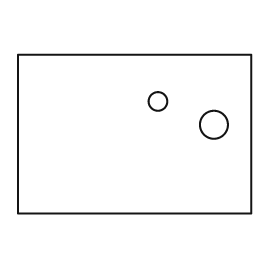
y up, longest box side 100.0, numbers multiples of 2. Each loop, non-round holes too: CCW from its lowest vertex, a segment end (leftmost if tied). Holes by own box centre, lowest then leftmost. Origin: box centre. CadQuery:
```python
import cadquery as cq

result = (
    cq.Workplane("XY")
    .moveTo(-50.0, -34.0)
    .lineTo(50.0, -34.0)
    .lineTo(50.0, 34.0)
    .lineTo(-50.0, 34.0)
    .close()
    .moveTo(34.0, 4.0)
    .circle(6.0)
    .moveTo(10.0, 14.0)
    .circle(4.0)
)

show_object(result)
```